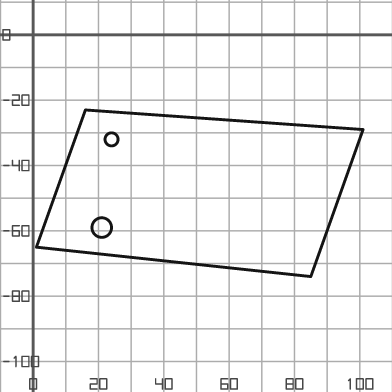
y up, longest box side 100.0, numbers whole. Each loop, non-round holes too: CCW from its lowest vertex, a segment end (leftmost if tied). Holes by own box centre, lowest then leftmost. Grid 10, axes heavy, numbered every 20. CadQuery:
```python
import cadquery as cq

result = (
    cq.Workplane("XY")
    .moveTo(85.0, -74.0)
    .lineTo(101.0, -29.0)
    .lineTo(16.0, -23.0)
    .lineTo(1.0, -65.0)
    .close()
    .moveTo(21.0, -59.0)
    .circle(3.0)
    .moveTo(24.0, -32.0)
    .circle(2.0)
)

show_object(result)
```